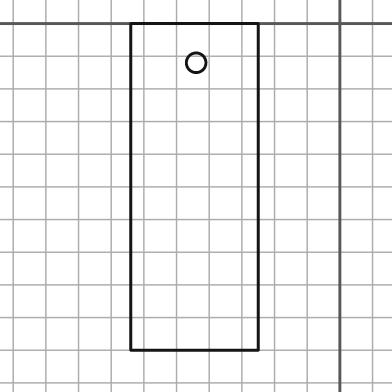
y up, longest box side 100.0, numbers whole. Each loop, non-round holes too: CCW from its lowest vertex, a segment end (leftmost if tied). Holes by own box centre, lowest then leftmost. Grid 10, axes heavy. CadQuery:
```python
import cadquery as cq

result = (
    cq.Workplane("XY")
    .moveTo(-64.0, -100.0)
    .lineTo(-25.0, -100.0)
    .lineTo(-25.0, 0.0)
    .lineTo(-64.0, 0.0)
    .close()
    .moveTo(-44.0, -12.0)
    .circle(3.0)
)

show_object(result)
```